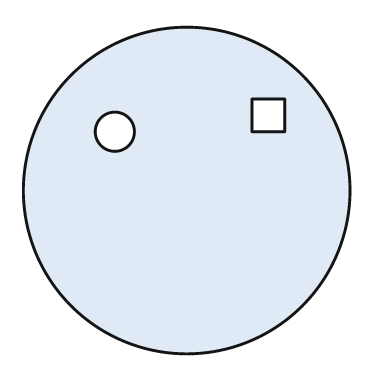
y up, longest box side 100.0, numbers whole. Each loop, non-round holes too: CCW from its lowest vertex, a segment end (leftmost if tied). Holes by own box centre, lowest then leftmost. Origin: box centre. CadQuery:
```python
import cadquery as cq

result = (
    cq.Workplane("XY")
    .moveTo(0.0, 0.0)
    .circle(50.0)
    .moveTo(-22.0, 18.0)
    .circle(6.0)
    .moveTo(20.0, 18.0)
    .lineTo(30.0, 18.0)
    .lineTo(30.0, 28.0)
    .lineTo(20.0, 28.0)
    .close()
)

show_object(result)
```